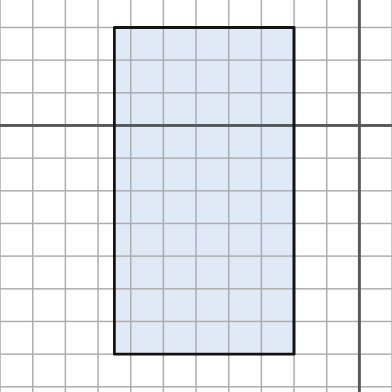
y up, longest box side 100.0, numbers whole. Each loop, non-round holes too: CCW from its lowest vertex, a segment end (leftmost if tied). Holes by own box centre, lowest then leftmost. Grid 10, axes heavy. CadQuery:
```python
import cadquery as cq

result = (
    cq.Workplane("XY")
    .moveTo(-75.0, -70.0)
    .lineTo(-20.0, -70.0)
    .lineTo(-20.0, 30.0)
    .lineTo(-75.0, 30.0)
    .close()
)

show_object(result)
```